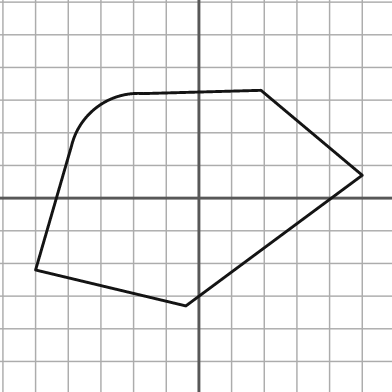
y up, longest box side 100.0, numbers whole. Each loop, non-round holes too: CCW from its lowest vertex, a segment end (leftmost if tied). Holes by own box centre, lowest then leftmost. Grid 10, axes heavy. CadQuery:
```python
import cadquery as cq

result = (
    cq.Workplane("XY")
    .moveTo(-4.0, -33.0)
    .lineTo(50.0, 7.0)
    .lineTo(19.0, 33.0)
    .lineTo(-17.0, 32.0)
    .threePointArc((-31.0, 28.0), (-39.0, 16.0))
    .lineTo(-50.0, -22.0)
    .close()
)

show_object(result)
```